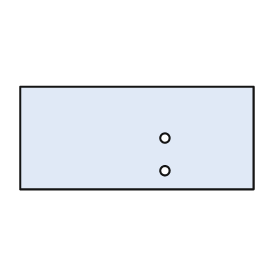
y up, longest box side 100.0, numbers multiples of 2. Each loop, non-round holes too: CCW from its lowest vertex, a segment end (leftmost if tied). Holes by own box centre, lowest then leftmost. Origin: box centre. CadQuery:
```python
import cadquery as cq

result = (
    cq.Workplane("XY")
    .moveTo(-50.0, -22.0)
    .lineTo(50.0, -22.0)
    .lineTo(50.0, 22.0)
    .lineTo(-50.0, 22.0)
    .close()
    .moveTo(12.0, -14.0)
    .circle(2.0)
    .moveTo(12.0, 0.0)
    .circle(2.0)
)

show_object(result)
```